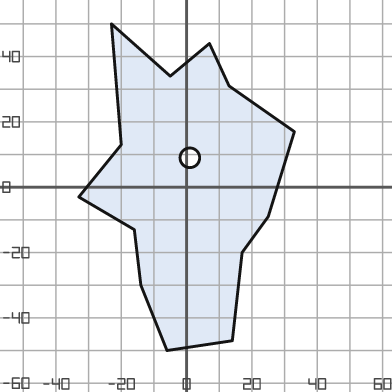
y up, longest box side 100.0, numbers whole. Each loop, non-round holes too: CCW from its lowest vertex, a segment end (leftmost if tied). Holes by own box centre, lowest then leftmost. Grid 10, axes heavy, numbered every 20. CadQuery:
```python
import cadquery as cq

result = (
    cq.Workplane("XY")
    .moveTo(-6.0, -50.0)
    .lineTo(14.0, -47.0)
    .lineTo(17.0, -20.0)
    .lineTo(25.0, -9.0)
    .lineTo(33.0, 17.0)
    .lineTo(13.0, 31.0)
    .lineTo(7.0, 44.0)
    .lineTo(-5.0, 34.0)
    .lineTo(-23.0, 50.0)
    .lineTo(-20.0, 13.0)
    .lineTo(-33.0, -3.0)
    .lineTo(-16.0, -13.0)
    .lineTo(-14.0, -30.0)
    .close()
    .moveTo(1.0, 9.0)
    .circle(3.0)
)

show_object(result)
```